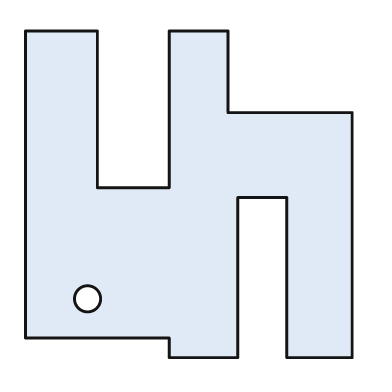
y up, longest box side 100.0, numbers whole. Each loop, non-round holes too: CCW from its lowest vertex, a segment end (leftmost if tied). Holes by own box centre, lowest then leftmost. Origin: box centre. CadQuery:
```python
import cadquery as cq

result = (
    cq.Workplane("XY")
    .moveTo(-6.0, -50.0)
    .lineTo(15.0, -50.0)
    .lineTo(15.0, -1.0)
    .lineTo(30.0, -1.0)
    .lineTo(30.0, -50.0)
    .lineTo(50.0, -50.0)
    .lineTo(50.0, 25.0)
    .lineTo(12.0, 25.0)
    .lineTo(12.0, 50.0)
    .lineTo(-6.0, 50.0)
    .lineTo(-6.0, 2.0)
    .lineTo(-28.0, 2.0)
    .lineTo(-28.0, 50.0)
    .lineTo(-50.0, 50.0)
    .lineTo(-50.0, -44.0)
    .lineTo(-6.0, -44.0)
    .close()
    .moveTo(-31.0, -32.0)
    .circle(4.0)
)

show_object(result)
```